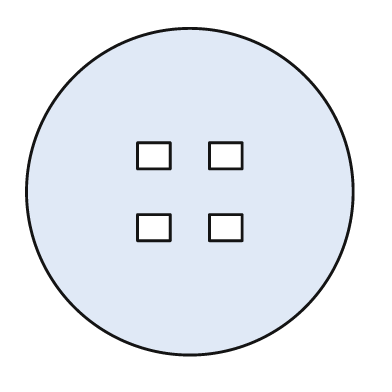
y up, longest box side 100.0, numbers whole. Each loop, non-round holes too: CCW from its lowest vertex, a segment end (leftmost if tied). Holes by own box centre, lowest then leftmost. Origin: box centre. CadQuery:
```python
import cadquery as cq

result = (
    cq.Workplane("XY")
    .moveTo(0.0, 0.0)
    .circle(50.0)
    .moveTo(-16.0, -15.0)
    .lineTo(-6.0, -15.0)
    .lineTo(-6.0, -7.0)
    .lineTo(-16.0, -7.0)
    .close()
    .moveTo(6.0, -15.0)
    .lineTo(16.0, -15.0)
    .lineTo(16.0, -7.0)
    .lineTo(6.0, -7.0)
    .close()
    .moveTo(-16.0, 7.0)
    .lineTo(-6.0, 7.0)
    .lineTo(-6.0, 15.0)
    .lineTo(-16.0, 15.0)
    .close()
    .moveTo(6.0, 7.0)
    .lineTo(16.0, 7.0)
    .lineTo(16.0, 15.0)
    .lineTo(6.0, 15.0)
    .close()
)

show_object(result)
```